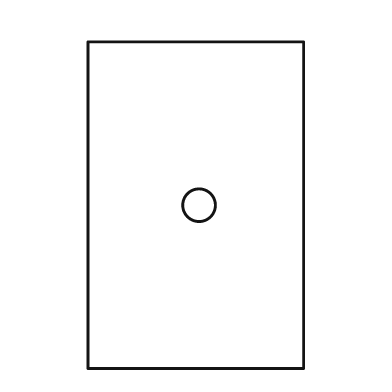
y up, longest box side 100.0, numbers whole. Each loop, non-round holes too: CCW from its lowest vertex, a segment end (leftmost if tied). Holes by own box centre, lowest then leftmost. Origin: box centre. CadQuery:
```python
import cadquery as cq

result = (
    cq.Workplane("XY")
    .moveTo(-33.0, -50.0)
    .lineTo(33.0, -50.0)
    .lineTo(33.0, 50.0)
    .lineTo(-33.0, 50.0)
    .close()
    .moveTo(1.0, 0.0)
    .circle(5.0)
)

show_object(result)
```